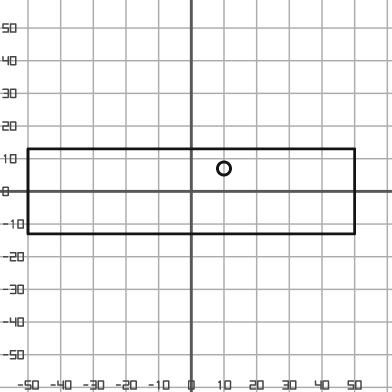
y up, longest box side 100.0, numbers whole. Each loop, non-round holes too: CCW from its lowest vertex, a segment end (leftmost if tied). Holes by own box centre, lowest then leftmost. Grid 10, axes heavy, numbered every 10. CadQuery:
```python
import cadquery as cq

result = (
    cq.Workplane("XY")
    .moveTo(-50.0, -13.0)
    .lineTo(50.0, -13.0)
    .lineTo(50.0, 13.0)
    .lineTo(-50.0, 13.0)
    .close()
    .moveTo(10.0, 7.0)
    .circle(2.0)
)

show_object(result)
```